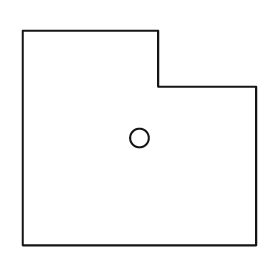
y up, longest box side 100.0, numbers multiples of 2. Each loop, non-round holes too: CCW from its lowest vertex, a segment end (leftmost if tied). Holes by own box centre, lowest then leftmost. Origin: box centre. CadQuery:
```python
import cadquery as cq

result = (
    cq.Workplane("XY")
    .moveTo(-50.0, -46.0)
    .lineTo(50.0, -46.0)
    .lineTo(50.0, 22.0)
    .lineTo(8.0, 22.0)
    .lineTo(8.0, 46.0)
    .lineTo(-50.0, 46.0)
    .close()
    .moveTo(0.0, 0.0)
    .circle(4.0)
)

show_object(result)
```